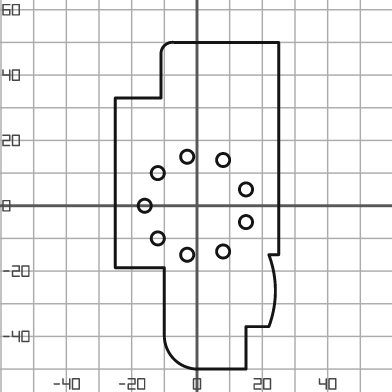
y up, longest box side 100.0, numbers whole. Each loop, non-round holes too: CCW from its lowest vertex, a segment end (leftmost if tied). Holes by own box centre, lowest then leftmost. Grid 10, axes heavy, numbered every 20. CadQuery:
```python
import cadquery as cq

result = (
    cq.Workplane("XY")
    .moveTo(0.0, -50.0)
    .lineTo(15.0, -50.0)
    .lineTo(15.0, -37.0)
    .lineTo(22.0, -37.0)
    .threePointArc((24.0, -26.0), (22.0, -15.0))
    .lineTo(25.0, -15.0)
    .lineTo(25.0, 50.0)
    .lineTo(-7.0, 50.0)
    .threePointArc((-10.0, 49.0), (-11.0, 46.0))
    .lineTo(-11.0, 33.0)
    .lineTo(-25.0, 33.0)
    .lineTo(-25.0, -19.0)
    .lineTo(-10.0, -19.0)
    .lineTo(-10.0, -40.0)
    .threePointArc((-7.0, -47.0), (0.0, -50.0))
    .close()
    .moveTo(-3.0, -15.0)
    .circle(2.0)
    .moveTo(8.0, -14.0)
    .circle(2.0)
    .moveTo(-12.0, -10.0)
    .circle(2.0)
    .moveTo(15.0, -5.0)
    .circle(2.0)
    .moveTo(-16.0, 0.0)
    .circle(2.0)
    .moveTo(15.0, 5.0)
    .circle(2.0)
    .moveTo(-12.0, 10.0)
    .circle(2.0)
    .moveTo(8.0, 14.0)
    .circle(2.0)
    .moveTo(-3.0, 15.0)
    .circle(2.0)
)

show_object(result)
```